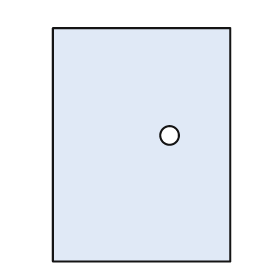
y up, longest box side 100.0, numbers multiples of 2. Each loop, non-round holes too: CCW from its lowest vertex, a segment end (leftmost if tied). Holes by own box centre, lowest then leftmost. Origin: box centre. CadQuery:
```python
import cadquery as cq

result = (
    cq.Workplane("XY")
    .moveTo(-38.0, -50.0)
    .lineTo(38.0, -50.0)
    .lineTo(38.0, 50.0)
    .lineTo(-38.0, 50.0)
    .close()
    .moveTo(12.0, 4.0)
    .circle(4.0)
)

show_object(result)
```